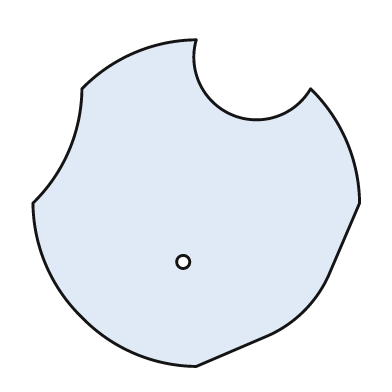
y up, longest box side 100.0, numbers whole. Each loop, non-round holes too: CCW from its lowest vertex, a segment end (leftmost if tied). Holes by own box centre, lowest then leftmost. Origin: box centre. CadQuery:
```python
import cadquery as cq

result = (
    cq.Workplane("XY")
    .moveTo(0.0, -50.0)
    .lineTo(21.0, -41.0)
    .threePointArc((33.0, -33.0), (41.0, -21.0))
    .lineTo(50.0, 0.0)
    .threePointArc((46.0, 19.0), (35.0, 35.0))
    .threePointArc((11.0, 27.0), (0.0, 50.0))
    .threePointArc((-19.0, 46.0), (-35.0, 35.0))
    .threePointArc((-39.0, 16.0), (-50.0, 0.0))
    .threePointArc((-46.0, -19.0), (-35.0, -35.0))
    .threePointArc((-19.0, -46.0), (0.0, -50.0))
    .close()
    .moveTo(-4.0, -18.0)
    .circle(2.0)
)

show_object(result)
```